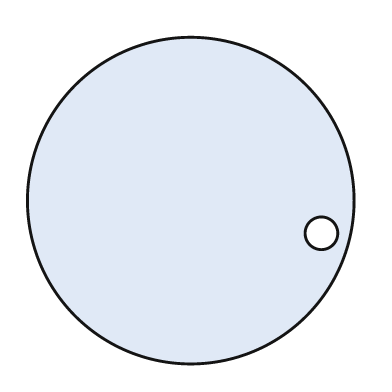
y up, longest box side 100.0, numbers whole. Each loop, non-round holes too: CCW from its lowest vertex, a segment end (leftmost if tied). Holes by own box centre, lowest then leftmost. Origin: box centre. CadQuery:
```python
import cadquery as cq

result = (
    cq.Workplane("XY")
    .moveTo(0.0, 0.0)
    .circle(50.0)
    .moveTo(40.0, -10.0)
    .circle(5.0)
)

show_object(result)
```